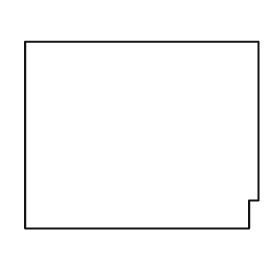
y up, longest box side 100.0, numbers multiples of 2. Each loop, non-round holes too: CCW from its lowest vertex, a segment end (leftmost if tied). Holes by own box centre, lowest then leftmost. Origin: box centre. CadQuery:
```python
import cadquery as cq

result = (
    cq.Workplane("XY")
    .moveTo(-50.0, -40.0)
    .lineTo(46.0, -40.0)
    .lineTo(46.0, -28.0)
    .lineTo(50.0, -28.0)
    .lineTo(50.0, 40.0)
    .lineTo(-50.0, 40.0)
    .close()
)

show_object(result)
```